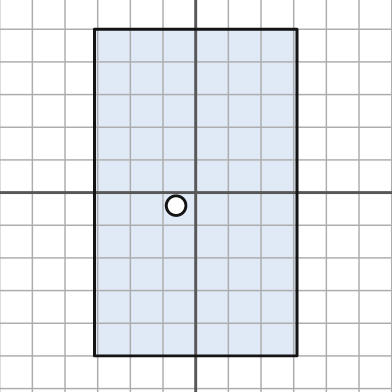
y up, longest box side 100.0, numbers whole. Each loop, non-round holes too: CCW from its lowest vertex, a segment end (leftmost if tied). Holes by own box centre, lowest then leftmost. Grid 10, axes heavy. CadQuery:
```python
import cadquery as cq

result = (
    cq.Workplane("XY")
    .moveTo(-31.0, -50.0)
    .lineTo(31.0, -50.0)
    .lineTo(31.0, 50.0)
    .lineTo(-31.0, 50.0)
    .close()
    .moveTo(-6.0, -4.0)
    .circle(3.0)
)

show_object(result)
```